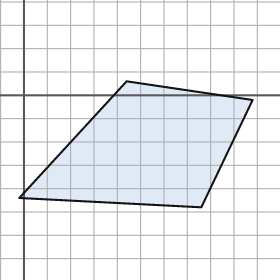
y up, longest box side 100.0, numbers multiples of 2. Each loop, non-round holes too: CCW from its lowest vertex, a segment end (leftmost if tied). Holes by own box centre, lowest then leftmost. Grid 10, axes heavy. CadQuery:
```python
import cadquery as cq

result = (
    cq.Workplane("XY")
    .moveTo(76.0, -48.0)
    .lineTo(98.0, -2.0)
    .lineTo(44.0, 6.0)
    .lineTo(-2.0, -44.0)
    .close()
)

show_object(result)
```